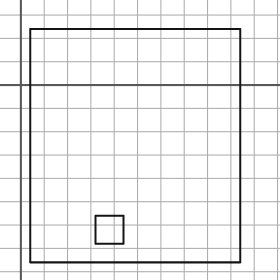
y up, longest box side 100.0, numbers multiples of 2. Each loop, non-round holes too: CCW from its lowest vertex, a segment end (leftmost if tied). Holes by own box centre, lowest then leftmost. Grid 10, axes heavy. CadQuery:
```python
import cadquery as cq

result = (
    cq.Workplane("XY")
    .moveTo(4.0, -76.0)
    .lineTo(94.0, -76.0)
    .lineTo(94.0, 24.0)
    .lineTo(4.0, 24.0)
    .close()
    .moveTo(32.0, -68.0)
    .lineTo(44.0, -68.0)
    .lineTo(44.0, -56.0)
    .lineTo(32.0, -56.0)
    .close()
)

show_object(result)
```